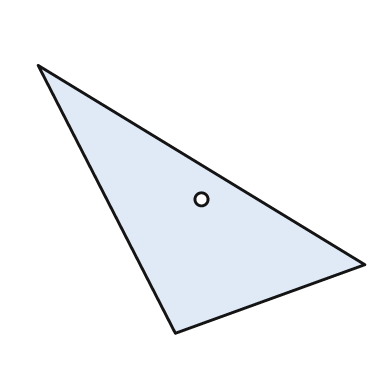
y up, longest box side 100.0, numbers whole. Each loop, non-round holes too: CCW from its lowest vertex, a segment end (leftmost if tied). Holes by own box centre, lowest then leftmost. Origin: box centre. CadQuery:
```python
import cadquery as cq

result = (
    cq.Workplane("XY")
    .moveTo(-8.0, -41.0)
    .lineTo(50.0, -20.0)
    .lineTo(-50.0, 41.0)
    .close()
    .moveTo(0.0, 0.0)
    .circle(2.0)
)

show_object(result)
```